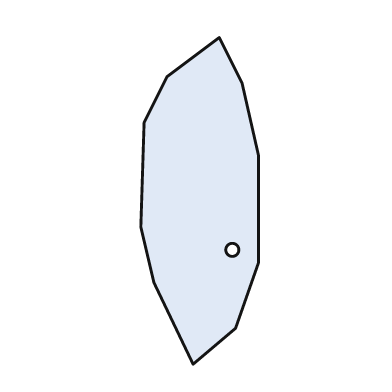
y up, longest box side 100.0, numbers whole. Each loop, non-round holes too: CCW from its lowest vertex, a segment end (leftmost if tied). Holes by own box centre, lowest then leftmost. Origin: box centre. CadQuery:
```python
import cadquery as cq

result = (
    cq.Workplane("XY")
    .moveTo(-2.0, -50.0)
    .lineTo(11.0, -39.0)
    .lineTo(18.0, -19.0)
    .lineTo(18.0, 14.0)
    .lineTo(13.0, 36.0)
    .lineTo(6.0, 50.0)
    .lineTo(-10.0, 38.0)
    .lineTo(-17.0, 24.0)
    .lineTo(-18.0, -8.0)
    .lineTo(-14.0, -25.0)
    .close()
    .moveTo(10.0, -15.0)
    .circle(2.0)
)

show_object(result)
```